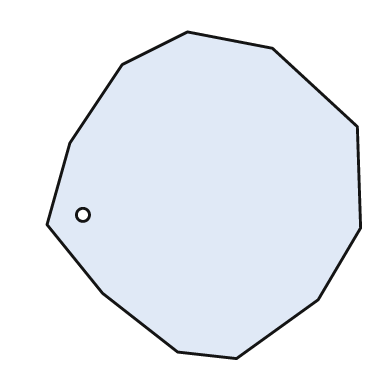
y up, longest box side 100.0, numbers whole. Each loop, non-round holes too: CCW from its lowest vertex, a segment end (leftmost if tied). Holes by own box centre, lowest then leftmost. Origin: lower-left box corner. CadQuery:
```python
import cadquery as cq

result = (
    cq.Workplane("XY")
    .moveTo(58.0, 0.0)
    .lineTo(83.0, 18.0)
    .lineTo(96.0, 40.0)
    .lineTo(95.0, 71.0)
    .lineTo(69.0, 95.0)
    .lineTo(43.0, 100.0)
    .lineTo(23.0, 90.0)
    .lineTo(7.0, 66.0)
    .lineTo(0.0, 41.0)
    .lineTo(17.0, 20.0)
    .lineTo(40.0, 2.0)
    .close()
    .moveTo(11.0, 44.0)
    .circle(2.0)
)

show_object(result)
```